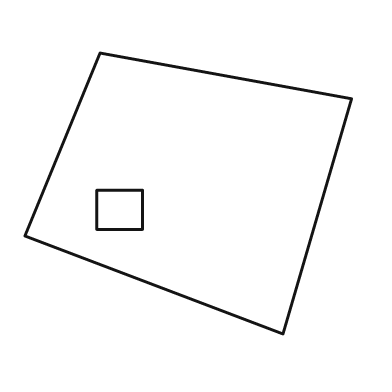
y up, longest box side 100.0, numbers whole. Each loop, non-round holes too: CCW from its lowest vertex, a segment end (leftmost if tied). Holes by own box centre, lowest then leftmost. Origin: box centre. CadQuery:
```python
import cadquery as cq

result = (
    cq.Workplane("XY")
    .moveTo(29.0, -43.0)
    .lineTo(50.0, 29.0)
    .lineTo(-27.0, 43.0)
    .lineTo(-50.0, -13.0)
    .close()
    .moveTo(-28.0, -11.0)
    .lineTo(-14.0, -11.0)
    .lineTo(-14.0, 1.0)
    .lineTo(-28.0, 1.0)
    .close()
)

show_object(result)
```